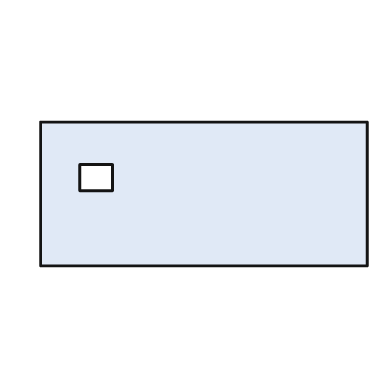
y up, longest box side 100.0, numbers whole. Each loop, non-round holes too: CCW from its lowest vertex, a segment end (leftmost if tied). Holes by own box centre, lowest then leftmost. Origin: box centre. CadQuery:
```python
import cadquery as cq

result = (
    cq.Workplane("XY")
    .moveTo(-50.0, -22.0)
    .lineTo(50.0, -22.0)
    .lineTo(50.0, 22.0)
    .lineTo(-50.0, 22.0)
    .close()
    .moveTo(-38.0, 1.0)
    .lineTo(-28.0, 1.0)
    .lineTo(-28.0, 9.0)
    .lineTo(-38.0, 9.0)
    .close()
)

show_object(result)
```